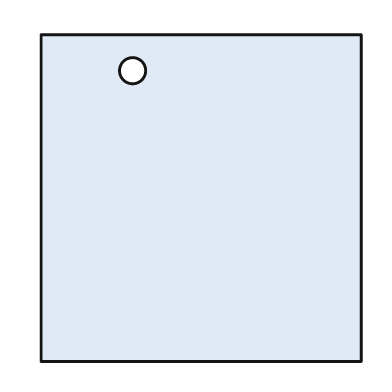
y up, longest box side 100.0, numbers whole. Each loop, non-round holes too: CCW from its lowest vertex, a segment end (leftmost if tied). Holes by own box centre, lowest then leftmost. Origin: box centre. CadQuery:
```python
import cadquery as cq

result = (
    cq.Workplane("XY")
    .moveTo(-49.0, -50.0)
    .lineTo(49.0, -50.0)
    .lineTo(49.0, 50.0)
    .lineTo(-49.0, 50.0)
    .close()
    .moveTo(-21.0, 39.0)
    .circle(4.0)
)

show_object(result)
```